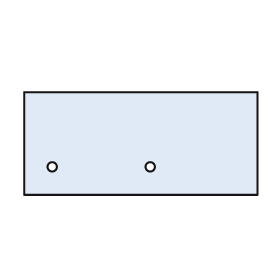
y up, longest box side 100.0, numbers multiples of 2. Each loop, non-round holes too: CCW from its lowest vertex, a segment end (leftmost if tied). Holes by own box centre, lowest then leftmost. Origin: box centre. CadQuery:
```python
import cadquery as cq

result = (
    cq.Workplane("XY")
    .moveTo(-50.0, -22.0)
    .lineTo(50.0, -22.0)
    .lineTo(50.0, 22.0)
    .lineTo(-50.0, 22.0)
    .close()
    .moveTo(-38.0, -10.0)
    .circle(2.0)
    .moveTo(4.0, -10.0)
    .circle(2.0)
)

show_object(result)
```